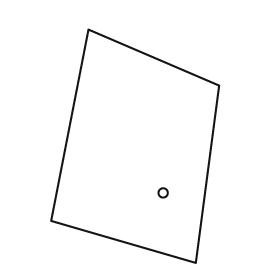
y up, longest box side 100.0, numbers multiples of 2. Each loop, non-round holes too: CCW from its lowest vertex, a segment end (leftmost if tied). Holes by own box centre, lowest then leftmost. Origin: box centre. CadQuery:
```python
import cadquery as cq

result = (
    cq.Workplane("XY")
    .moveTo(26.0, -50.0)
    .lineTo(36.0, 26.0)
    .lineTo(-20.0, 50.0)
    .lineTo(-36.0, -32.0)
    .close()
    .moveTo(12.0, -20.0)
    .circle(2.0)
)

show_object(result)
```